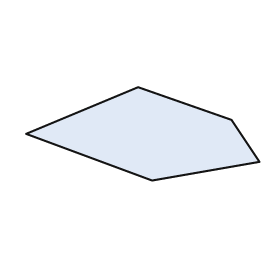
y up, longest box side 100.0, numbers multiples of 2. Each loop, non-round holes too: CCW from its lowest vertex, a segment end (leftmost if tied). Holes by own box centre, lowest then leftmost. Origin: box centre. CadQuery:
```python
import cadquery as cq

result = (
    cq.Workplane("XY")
    .moveTo(4.0, -20.0)
    .lineTo(50.0, -12.0)
    .lineTo(38.0, 6.0)
    .lineTo(-2.0, 20.0)
    .lineTo(-50.0, 0.0)
    .close()
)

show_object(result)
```